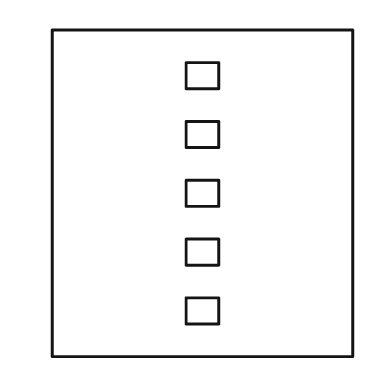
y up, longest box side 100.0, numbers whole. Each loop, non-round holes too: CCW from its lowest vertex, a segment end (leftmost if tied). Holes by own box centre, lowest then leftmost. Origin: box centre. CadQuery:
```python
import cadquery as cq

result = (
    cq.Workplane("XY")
    .moveTo(-46.0, -50.0)
    .lineTo(46.0, -50.0)
    .lineTo(46.0, 50.0)
    .lineTo(-46.0, 50.0)
    .close()
    .moveTo(-5.0, -40.0)
    .lineTo(5.0, -40.0)
    .lineTo(5.0, -32.0)
    .lineTo(-5.0, -32.0)
    .close()
    .moveTo(-5.0, -22.0)
    .lineTo(5.0, -22.0)
    .lineTo(5.0, -14.0)
    .lineTo(-5.0, -14.0)
    .close()
    .moveTo(-5.0, -4.0)
    .lineTo(5.0, -4.0)
    .lineTo(5.0, 4.0)
    .lineTo(-5.0, 4.0)
    .close()
    .moveTo(-5.0, 14.0)
    .lineTo(5.0, 14.0)
    .lineTo(5.0, 22.0)
    .lineTo(-5.0, 22.0)
    .close()
    .moveTo(-5.0, 32.0)
    .lineTo(5.0, 32.0)
    .lineTo(5.0, 40.0)
    .lineTo(-5.0, 40.0)
    .close()
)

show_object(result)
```